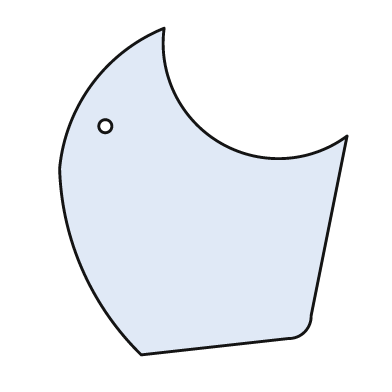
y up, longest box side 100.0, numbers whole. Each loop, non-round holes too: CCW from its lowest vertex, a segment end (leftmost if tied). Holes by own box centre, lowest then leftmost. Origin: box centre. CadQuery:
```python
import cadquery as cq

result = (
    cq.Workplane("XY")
    .moveTo(-19.0, -50.0)
    .lineTo(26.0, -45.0)
    .threePointArc((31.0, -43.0), (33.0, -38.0))
    .lineTo(44.0, 17.0)
    .threePointArc((5.0, 15.0), (-12.0, 50.0))
    .threePointArc((-34.0, 33.0), (-44.0, 7.0))
    .threePointArc((-37.0, -24.0), (-19.0, -50.0))
    .close()
    .moveTo(-30.0, 20.0)
    .circle(2.0)
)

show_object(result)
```